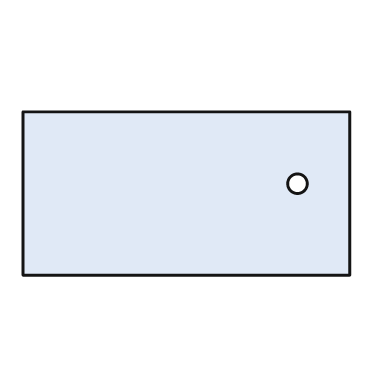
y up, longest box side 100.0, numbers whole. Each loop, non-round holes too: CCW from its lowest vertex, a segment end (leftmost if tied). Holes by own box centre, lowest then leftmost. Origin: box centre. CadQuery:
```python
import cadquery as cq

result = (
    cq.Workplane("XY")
    .moveTo(-50.0, -25.0)
    .lineTo(50.0, -25.0)
    .lineTo(50.0, 25.0)
    .lineTo(-50.0, 25.0)
    .close()
    .moveTo(34.0, 3.0)
    .circle(3.0)
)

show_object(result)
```